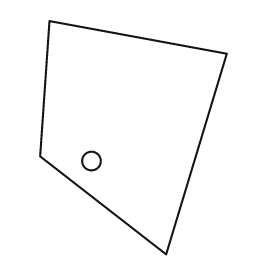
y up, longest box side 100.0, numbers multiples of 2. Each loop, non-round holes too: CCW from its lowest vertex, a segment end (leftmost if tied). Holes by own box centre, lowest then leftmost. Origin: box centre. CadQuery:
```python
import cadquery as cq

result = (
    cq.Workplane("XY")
    .moveTo(14.0, -50.0)
    .lineTo(40.0, 36.0)
    .lineTo(-36.0, 50.0)
    .lineTo(-40.0, -8.0)
    .close()
    .moveTo(-18.0, -10.0)
    .circle(4.0)
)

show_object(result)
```